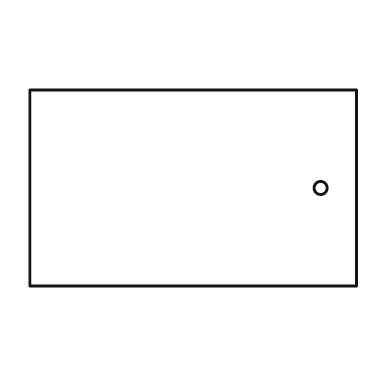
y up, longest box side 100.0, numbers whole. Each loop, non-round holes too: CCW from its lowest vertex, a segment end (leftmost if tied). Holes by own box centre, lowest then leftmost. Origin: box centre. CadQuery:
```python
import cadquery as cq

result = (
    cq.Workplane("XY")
    .moveTo(-50.0, -30.0)
    .lineTo(50.0, -30.0)
    .lineTo(50.0, 30.0)
    .lineTo(-50.0, 30.0)
    .close()
    .moveTo(39.0, 0.0)
    .circle(2.0)
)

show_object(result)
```